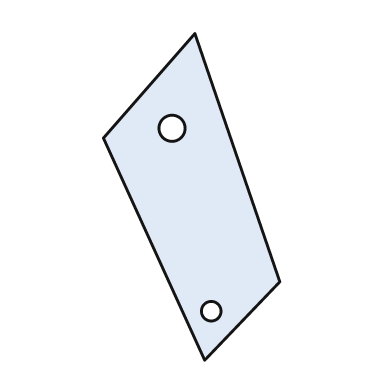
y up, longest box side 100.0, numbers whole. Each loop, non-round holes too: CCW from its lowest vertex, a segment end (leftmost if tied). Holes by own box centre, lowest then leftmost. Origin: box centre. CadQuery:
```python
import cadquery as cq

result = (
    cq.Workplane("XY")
    .moveTo(4.0, -50.0)
    .lineTo(27.0, -26.0)
    .lineTo(1.0, 50.0)
    .lineTo(-27.0, 18.0)
    .close()
    .moveTo(6.0, -35.0)
    .circle(3.0)
    .moveTo(-6.0, 21.0)
    .circle(4.0)
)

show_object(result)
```